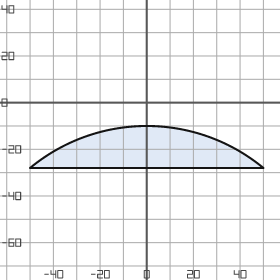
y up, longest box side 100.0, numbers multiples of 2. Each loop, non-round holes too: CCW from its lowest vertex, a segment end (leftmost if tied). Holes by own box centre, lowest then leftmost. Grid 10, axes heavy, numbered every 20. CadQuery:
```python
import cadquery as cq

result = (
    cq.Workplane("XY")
    .moveTo(-50.0, -28.0)
    .lineTo(50.0, -28.0)
    .threePointArc((0.0, -10.0), (-50.0, -28.0))
    .close()
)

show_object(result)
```